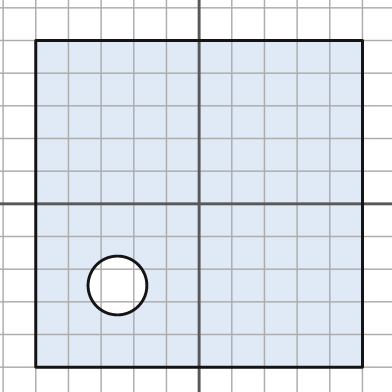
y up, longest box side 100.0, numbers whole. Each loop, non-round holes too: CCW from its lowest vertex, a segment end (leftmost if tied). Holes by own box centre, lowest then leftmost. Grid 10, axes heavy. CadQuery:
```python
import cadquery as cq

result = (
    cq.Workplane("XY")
    .moveTo(-50.0, -50.0)
    .lineTo(50.0, -50.0)
    .lineTo(50.0, 50.0)
    .lineTo(-50.0, 50.0)
    .close()
    .moveTo(-25.0, -25.0)
    .circle(9.0)
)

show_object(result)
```